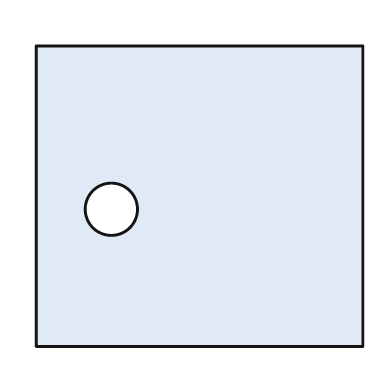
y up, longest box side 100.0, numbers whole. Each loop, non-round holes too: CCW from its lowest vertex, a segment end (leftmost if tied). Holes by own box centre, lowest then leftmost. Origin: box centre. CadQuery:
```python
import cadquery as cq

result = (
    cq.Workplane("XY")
    .moveTo(-50.0, -46.0)
    .lineTo(50.0, -46.0)
    .lineTo(50.0, 46.0)
    .lineTo(-50.0, 46.0)
    .close()
    .moveTo(-27.0, -4.0)
    .circle(8.0)
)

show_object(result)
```